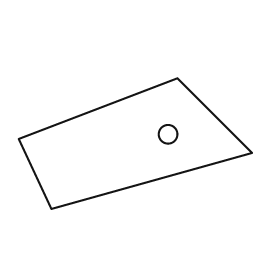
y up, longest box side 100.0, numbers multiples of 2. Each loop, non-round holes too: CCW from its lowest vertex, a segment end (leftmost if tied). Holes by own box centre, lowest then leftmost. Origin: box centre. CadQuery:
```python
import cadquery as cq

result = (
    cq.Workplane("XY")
    .moveTo(-36.0, -28.0)
    .lineTo(50.0, -4.0)
    .lineTo(18.0, 28.0)
    .lineTo(-50.0, 2.0)
    .close()
    .moveTo(14.0, 4.0)
    .circle(4.0)
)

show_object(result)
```